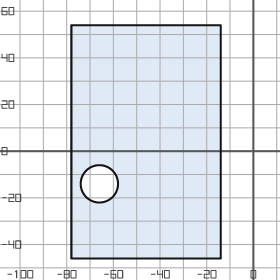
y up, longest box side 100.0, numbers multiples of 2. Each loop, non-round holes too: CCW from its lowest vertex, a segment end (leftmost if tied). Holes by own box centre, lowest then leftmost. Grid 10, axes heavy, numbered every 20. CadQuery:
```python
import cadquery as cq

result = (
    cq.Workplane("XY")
    .moveTo(-78.0, -46.0)
    .lineTo(-14.0, -46.0)
    .lineTo(-14.0, 54.0)
    .lineTo(-78.0, 54.0)
    .close()
    .moveTo(-66.0, -14.0)
    .circle(8.0)
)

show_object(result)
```